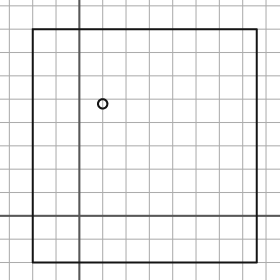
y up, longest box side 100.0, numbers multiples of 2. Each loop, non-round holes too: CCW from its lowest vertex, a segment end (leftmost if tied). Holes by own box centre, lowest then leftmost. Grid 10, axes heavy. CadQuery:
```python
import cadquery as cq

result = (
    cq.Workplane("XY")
    .moveTo(-20.0, -20.0)
    .lineTo(76.0, -20.0)
    .lineTo(76.0, 80.0)
    .lineTo(-20.0, 80.0)
    .close()
    .moveTo(10.0, 48.0)
    .circle(2.0)
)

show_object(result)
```